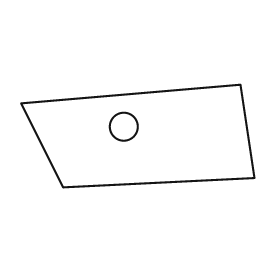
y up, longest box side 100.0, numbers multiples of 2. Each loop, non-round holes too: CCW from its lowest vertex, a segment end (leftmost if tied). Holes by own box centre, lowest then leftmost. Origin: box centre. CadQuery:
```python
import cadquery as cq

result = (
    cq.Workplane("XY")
    .moveTo(-32.0, -22.0)
    .lineTo(50.0, -18.0)
    .lineTo(44.0, 22.0)
    .lineTo(-50.0, 14.0)
    .close()
    .moveTo(-6.0, 4.0)
    .circle(6.0)
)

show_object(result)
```